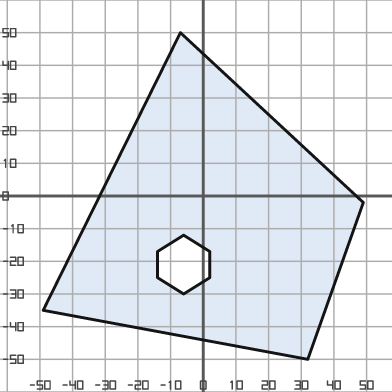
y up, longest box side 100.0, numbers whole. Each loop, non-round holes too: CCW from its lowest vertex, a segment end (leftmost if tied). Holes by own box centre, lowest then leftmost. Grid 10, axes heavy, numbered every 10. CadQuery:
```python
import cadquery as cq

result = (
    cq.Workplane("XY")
    .moveTo(32.0, -50.0)
    .lineTo(49.0, -2.0)
    .lineTo(-7.0, 50.0)
    .lineTo(-49.0, -35.0)
    .close()
    .moveTo(-6.0, -30.0)
    .lineTo(2.0, -25.0)
    .lineTo(2.0, -17.0)
    .lineTo(-6.0, -12.0)
    .lineTo(-14.0, -17.0)
    .lineTo(-14.0, -25.0)
    .close()
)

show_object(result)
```